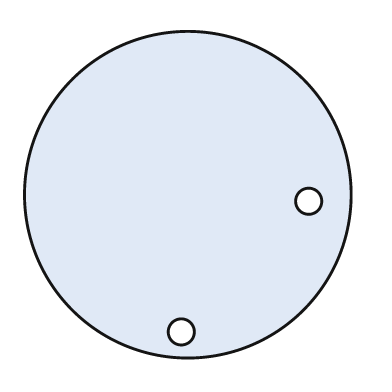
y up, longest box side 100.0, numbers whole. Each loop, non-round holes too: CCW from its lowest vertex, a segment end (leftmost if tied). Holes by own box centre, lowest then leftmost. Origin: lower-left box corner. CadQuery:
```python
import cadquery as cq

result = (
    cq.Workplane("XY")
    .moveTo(50.0, 50.0)
    .circle(50.0)
    .moveTo(48.0, 8.0)
    .circle(4.0)
    .moveTo(87.0, 48.0)
    .circle(4.0)
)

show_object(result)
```